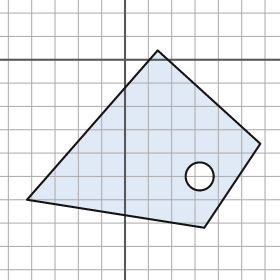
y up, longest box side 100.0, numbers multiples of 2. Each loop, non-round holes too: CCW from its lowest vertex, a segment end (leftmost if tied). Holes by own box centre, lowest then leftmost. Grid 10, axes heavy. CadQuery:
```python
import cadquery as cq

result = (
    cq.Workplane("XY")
    .moveTo(34.0, -72.0)
    .lineTo(58.0, -36.0)
    .lineTo(14.0, 4.0)
    .lineTo(-42.0, -60.0)
    .close()
    .moveTo(32.0, -50.0)
    .circle(6.0)
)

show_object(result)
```